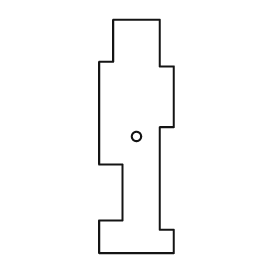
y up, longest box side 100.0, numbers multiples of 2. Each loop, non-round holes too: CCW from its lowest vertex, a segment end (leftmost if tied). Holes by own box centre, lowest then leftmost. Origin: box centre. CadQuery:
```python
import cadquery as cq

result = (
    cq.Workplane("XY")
    .moveTo(-16.0, -50.0)
    .lineTo(16.0, -50.0)
    .lineTo(16.0, -40.0)
    .lineTo(10.0, -40.0)
    .lineTo(10.0, 4.0)
    .lineTo(16.0, 4.0)
    .lineTo(16.0, 30.0)
    .lineTo(10.0, 30.0)
    .lineTo(10.0, 50.0)
    .lineTo(-10.0, 50.0)
    .lineTo(-10.0, 32.0)
    .lineTo(-16.0, 32.0)
    .lineTo(-16.0, -12.0)
    .lineTo(-6.0, -12.0)
    .lineTo(-6.0, -36.0)
    .lineTo(-16.0, -36.0)
    .close()
    .moveTo(0.0, 0.0)
    .circle(2.0)
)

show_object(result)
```